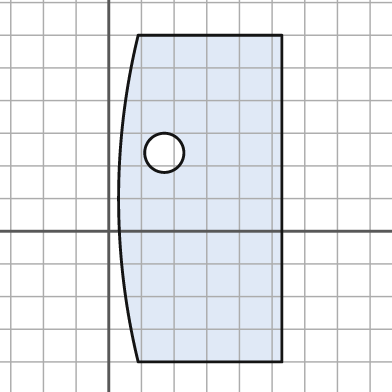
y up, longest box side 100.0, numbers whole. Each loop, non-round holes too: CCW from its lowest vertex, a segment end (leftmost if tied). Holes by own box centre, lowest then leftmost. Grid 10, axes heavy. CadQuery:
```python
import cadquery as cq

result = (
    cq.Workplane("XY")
    .moveTo(9.0, -40.0)
    .lineTo(53.0, -40.0)
    .lineTo(53.0, 60.0)
    .lineTo(9.0, 60.0)
    .threePointArc((3.0, 10.0), (9.0, -40.0))
    .close()
    .moveTo(17.0, 24.0)
    .circle(6.0)
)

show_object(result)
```